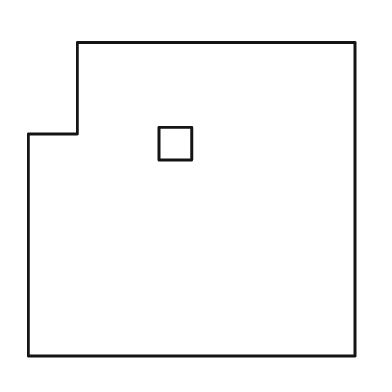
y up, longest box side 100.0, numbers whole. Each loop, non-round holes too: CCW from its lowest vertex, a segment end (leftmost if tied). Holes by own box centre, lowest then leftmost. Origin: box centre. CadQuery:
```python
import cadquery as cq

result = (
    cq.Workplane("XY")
    .moveTo(-50.0, -48.0)
    .lineTo(50.0, -48.0)
    .lineTo(50.0, 48.0)
    .lineTo(-35.0, 48.0)
    .lineTo(-35.0, 20.0)
    .lineTo(-50.0, 20.0)
    .close()
    .moveTo(-10.0, 12.0)
    .lineTo(0.0, 12.0)
    .lineTo(0.0, 22.0)
    .lineTo(-10.0, 22.0)
    .close()
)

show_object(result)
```